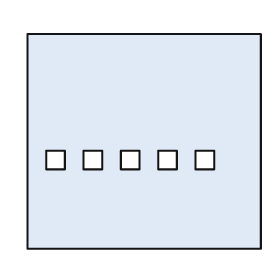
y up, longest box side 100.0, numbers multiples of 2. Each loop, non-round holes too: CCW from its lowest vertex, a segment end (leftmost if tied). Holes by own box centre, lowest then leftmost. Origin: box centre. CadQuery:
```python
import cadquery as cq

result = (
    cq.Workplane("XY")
    .moveTo(-50.0, -46.0)
    .lineTo(50.0, -46.0)
    .lineTo(50.0, 46.0)
    .lineTo(-50.0, 46.0)
    .close()
    .moveTo(-42.0, -12.0)
    .lineTo(-34.0, -12.0)
    .lineTo(-34.0, -4.0)
    .lineTo(-42.0, -4.0)
    .close()
    .moveTo(-26.0, -12.0)
    .lineTo(-18.0, -12.0)
    .lineTo(-18.0, -4.0)
    .lineTo(-26.0, -4.0)
    .close()
    .moveTo(-10.0, -12.0)
    .lineTo(-2.0, -12.0)
    .lineTo(-2.0, -4.0)
    .lineTo(-10.0, -4.0)
    .close()
    .moveTo(6.0, -12.0)
    .lineTo(14.0, -12.0)
    .lineTo(14.0, -4.0)
    .lineTo(6.0, -4.0)
    .close()
    .moveTo(22.0, -12.0)
    .lineTo(30.0, -12.0)
    .lineTo(30.0, -4.0)
    .lineTo(22.0, -4.0)
    .close()
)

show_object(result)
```